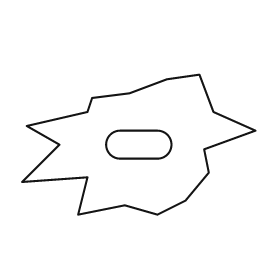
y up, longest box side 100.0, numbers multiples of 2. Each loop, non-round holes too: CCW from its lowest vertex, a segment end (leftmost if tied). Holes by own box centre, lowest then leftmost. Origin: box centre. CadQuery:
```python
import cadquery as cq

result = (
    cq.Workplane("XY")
    .moveTo(-26.0, -30.0)
    .lineTo(-6.0, -26.0)
    .lineTo(8.0, -30.0)
    .lineTo(20.0, -24.0)
    .lineTo(30.0, -12.0)
    .lineTo(28.0, -2.0)
    .lineTo(50.0, 6.0)
    .lineTo(32.0, 14.0)
    .lineTo(26.0, 30.0)
    .lineTo(12.0, 28.0)
    .lineTo(-4.0, 22.0)
    .lineTo(-20.0, 20.0)
    .lineTo(-22.0, 14.0)
    .lineTo(-48.0, 8.0)
    .lineTo(-34.0, 0.0)
    .lineTo(-50.0, -16.0)
    .lineTo(-22.0, -14.0)
    .close()
    .moveTo(-8.0, -6.0)
    .lineTo(8.0, -6.0)
    .threePointArc((14.0, 0.0), (8.0, 6.0))
    .lineTo(-8.0, 6.0)
    .threePointArc((-14.0, 0.0), (-8.0, -6.0))
    .close()
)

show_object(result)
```